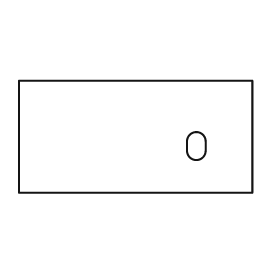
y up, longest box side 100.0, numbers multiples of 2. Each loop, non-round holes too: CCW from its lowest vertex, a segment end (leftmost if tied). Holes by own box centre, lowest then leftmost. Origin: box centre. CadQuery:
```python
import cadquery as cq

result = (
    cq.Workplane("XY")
    .moveTo(-50.0, -24.0)
    .lineTo(50.0, -24.0)
    .lineTo(50.0, 24.0)
    .lineTo(-50.0, 24.0)
    .close()
    .moveTo(22.0, -6.0)
    .threePointArc((26.0, -10.0), (30.0, -6.0))
    .lineTo(30.0, -2.0)
    .threePointArc((26.0, 2.0), (22.0, -2.0))
    .close()
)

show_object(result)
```